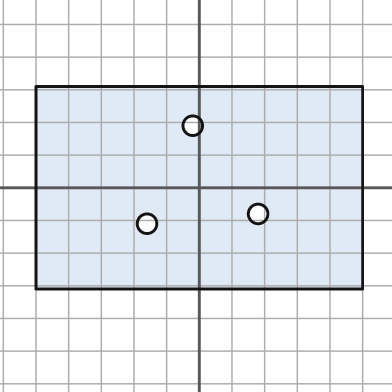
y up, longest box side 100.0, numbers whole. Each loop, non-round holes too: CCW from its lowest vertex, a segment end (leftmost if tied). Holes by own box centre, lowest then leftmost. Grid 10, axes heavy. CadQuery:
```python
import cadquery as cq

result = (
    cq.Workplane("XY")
    .moveTo(-50.0, -31.0)
    .lineTo(50.0, -31.0)
    .lineTo(50.0, 31.0)
    .lineTo(-50.0, 31.0)
    .close()
    .moveTo(-16.0, -11.0)
    .circle(3.0)
    .moveTo(18.0, -8.0)
    .circle(3.0)
    .moveTo(-2.0, 19.0)
    .circle(3.0)
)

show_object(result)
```